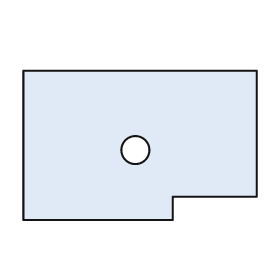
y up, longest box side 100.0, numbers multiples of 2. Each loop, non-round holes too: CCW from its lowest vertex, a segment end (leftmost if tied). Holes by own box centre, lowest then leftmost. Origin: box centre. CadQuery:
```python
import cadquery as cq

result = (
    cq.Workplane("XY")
    .moveTo(-50.0, -32.0)
    .lineTo(14.0, -32.0)
    .lineTo(14.0, -22.0)
    .lineTo(50.0, -22.0)
    .lineTo(50.0, 32.0)
    .lineTo(-50.0, 32.0)
    .close()
    .moveTo(-2.0, -2.0)
    .circle(6.0)
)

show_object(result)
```